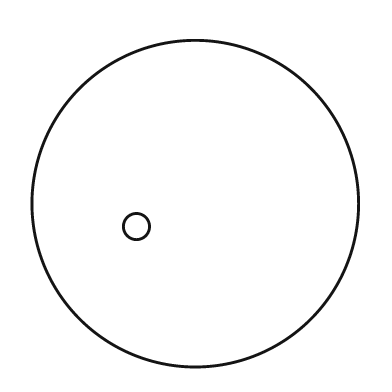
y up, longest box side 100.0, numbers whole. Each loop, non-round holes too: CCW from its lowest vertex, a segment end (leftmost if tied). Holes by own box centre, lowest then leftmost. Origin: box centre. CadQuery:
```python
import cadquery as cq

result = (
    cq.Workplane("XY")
    .moveTo(0.0, 0.0)
    .circle(50.0)
    .moveTo(-18.0, -7.0)
    .circle(4.0)
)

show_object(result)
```